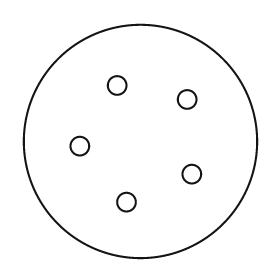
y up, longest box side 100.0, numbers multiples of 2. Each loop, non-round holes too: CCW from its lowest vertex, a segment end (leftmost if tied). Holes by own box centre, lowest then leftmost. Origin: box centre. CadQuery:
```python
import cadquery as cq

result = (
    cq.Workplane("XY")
    .moveTo(0.0, 0.0)
    .circle(50.0)
    .moveTo(-6.0, -26.0)
    .circle(4.0)
    .moveTo(22.0, -14.0)
    .circle(4.0)
    .moveTo(-26.0, -2.0)
    .circle(4.0)
    .moveTo(20.0, 18.0)
    .circle(4.0)
    .moveTo(-10.0, 24.0)
    .circle(4.0)
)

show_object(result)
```